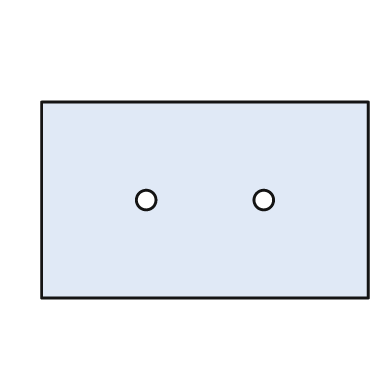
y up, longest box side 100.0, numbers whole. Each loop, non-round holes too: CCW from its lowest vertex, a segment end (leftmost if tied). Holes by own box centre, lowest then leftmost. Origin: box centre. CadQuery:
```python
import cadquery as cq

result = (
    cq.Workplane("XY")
    .moveTo(-50.0, -30.0)
    .lineTo(50.0, -30.0)
    .lineTo(50.0, 30.0)
    .lineTo(-50.0, 30.0)
    .close()
    .moveTo(-18.0, 0.0)
    .circle(3.0)
    .moveTo(18.0, 0.0)
    .circle(3.0)
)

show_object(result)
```